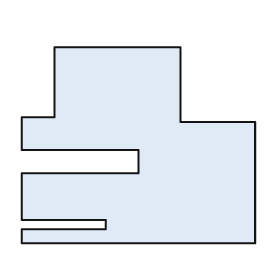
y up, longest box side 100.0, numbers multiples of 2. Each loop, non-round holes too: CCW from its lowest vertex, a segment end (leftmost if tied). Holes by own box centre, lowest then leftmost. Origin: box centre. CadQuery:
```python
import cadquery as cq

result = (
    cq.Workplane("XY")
    .moveTo(-50.0, -42.0)
    .lineTo(50.0, -42.0)
    .lineTo(50.0, 10.0)
    .lineTo(18.0, 10.0)
    .lineTo(18.0, 42.0)
    .lineTo(-36.0, 42.0)
    .lineTo(-36.0, 12.0)
    .lineTo(-50.0, 12.0)
    .lineTo(-50.0, -2.0)
    .lineTo(0.0, -2.0)
    .lineTo(0.0, -12.0)
    .lineTo(-50.0, -12.0)
    .lineTo(-50.0, -32.0)
    .lineTo(-14.0, -32.0)
    .lineTo(-14.0, -36.0)
    .lineTo(-50.0, -36.0)
    .close()
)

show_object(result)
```